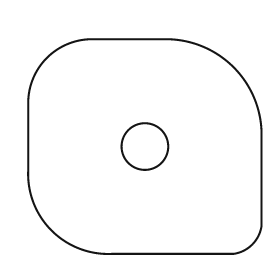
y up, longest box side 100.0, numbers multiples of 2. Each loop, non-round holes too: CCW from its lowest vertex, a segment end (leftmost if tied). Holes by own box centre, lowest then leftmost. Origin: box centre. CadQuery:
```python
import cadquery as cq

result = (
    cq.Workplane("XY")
    .moveTo(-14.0, -46.0)
    .lineTo(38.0, -46.0)
    .threePointArc((46.0, -42.0), (50.0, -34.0))
    .lineTo(50.0, 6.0)
    .threePointArc((38.0, 34.0), (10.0, 46.0))
    .lineTo(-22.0, 46.0)
    .threePointArc((-42.0, 38.0), (-50.0, 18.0))
    .lineTo(-50.0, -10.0)
    .threePointArc((-40.0, -36.0), (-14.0, -46.0))
    .close()
    .moveTo(0.0, 0.0)
    .circle(10.0)
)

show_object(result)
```